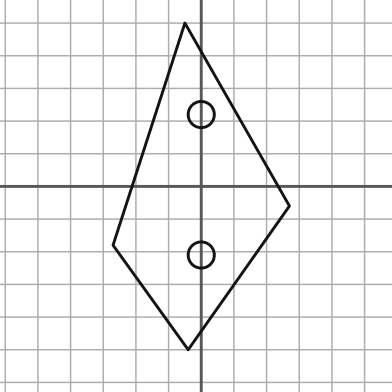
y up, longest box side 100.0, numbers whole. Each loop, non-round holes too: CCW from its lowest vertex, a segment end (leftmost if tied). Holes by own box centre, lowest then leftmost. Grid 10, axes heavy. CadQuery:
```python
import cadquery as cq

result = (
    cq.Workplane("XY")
    .moveTo(-4.0, -50.0)
    .lineTo(27.0, -6.0)
    .lineTo(-5.0, 50.0)
    .lineTo(-27.0, -18.0)
    .close()
    .moveTo(0.0, -21.0)
    .circle(4.0)
    .moveTo(0.0, 22.0)
    .circle(4.0)
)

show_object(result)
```